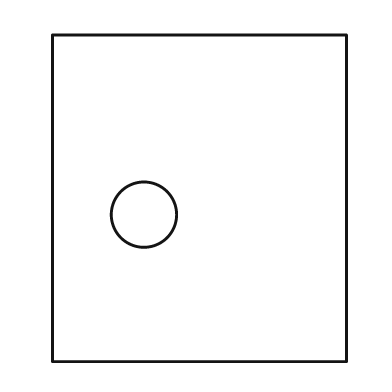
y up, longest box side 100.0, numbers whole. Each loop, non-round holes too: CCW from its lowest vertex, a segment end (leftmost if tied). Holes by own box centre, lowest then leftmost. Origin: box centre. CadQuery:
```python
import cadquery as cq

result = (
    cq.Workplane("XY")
    .moveTo(-45.0, -50.0)
    .lineTo(45.0, -50.0)
    .lineTo(45.0, 50.0)
    .lineTo(-45.0, 50.0)
    .close()
    .moveTo(-17.0, -5.0)
    .circle(10.0)
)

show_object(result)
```